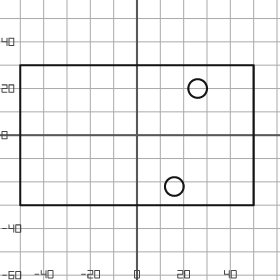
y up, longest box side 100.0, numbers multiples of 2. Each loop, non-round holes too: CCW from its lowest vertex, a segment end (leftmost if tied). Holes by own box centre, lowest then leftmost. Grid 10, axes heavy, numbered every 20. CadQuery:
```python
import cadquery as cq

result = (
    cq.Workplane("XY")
    .moveTo(-50.0, -30.0)
    .lineTo(50.0, -30.0)
    .lineTo(50.0, 30.0)
    .lineTo(-50.0, 30.0)
    .close()
    .moveTo(16.0, -22.0)
    .circle(4.0)
    .moveTo(26.0, 20.0)
    .circle(4.0)
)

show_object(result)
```